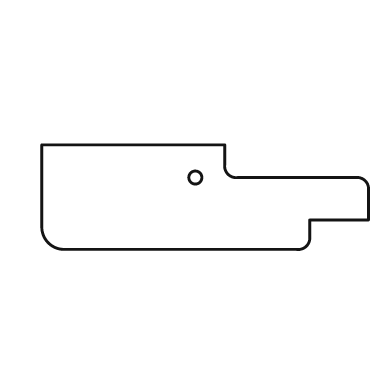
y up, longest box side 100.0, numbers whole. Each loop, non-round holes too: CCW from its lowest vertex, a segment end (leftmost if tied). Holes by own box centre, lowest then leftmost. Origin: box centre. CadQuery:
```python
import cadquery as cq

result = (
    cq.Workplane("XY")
    .moveTo(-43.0, -16.0)
    .lineTo(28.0, -16.0)
    .threePointArc((31.0, -15.0), (32.0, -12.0))
    .lineTo(32.0, -7.0)
    .lineTo(50.0, -7.0)
    .lineTo(50.0, 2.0)
    .threePointArc((49.0, 5.0), (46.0, 6.0))
    .lineTo(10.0, 6.0)
    .threePointArc((7.0, 7.0), (6.0, 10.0))
    .lineTo(6.0, 16.0)
    .lineTo(-50.0, 16.0)
    .lineTo(-50.0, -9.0)
    .threePointArc((-48.0, -14.0), (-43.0, -16.0))
    .close()
    .moveTo(-3.0, 6.0)
    .circle(2.0)
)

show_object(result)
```